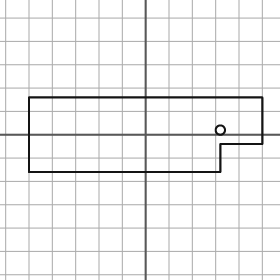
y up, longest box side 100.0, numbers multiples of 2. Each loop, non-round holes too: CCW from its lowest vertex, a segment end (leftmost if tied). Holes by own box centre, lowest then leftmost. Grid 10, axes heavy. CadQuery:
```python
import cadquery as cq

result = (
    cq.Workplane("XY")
    .moveTo(-50.0, -16.0)
    .lineTo(32.0, -16.0)
    .lineTo(32.0, -4.0)
    .lineTo(50.0, -4.0)
    .lineTo(50.0, 16.0)
    .lineTo(-50.0, 16.0)
    .close()
    .moveTo(32.0, 2.0)
    .circle(2.0)
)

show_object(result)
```